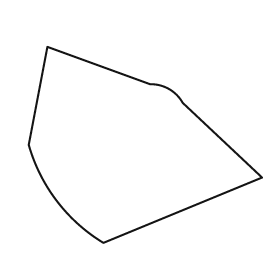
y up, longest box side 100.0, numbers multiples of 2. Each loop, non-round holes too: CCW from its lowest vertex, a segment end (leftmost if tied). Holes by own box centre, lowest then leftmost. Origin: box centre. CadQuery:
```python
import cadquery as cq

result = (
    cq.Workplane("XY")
    .moveTo(-18.0, -42.0)
    .lineTo(50.0, -14.0)
    .lineTo(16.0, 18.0)
    .threePointArc((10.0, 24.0), (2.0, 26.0))
    .lineTo(-42.0, 42.0)
    .lineTo(-50.0, 0.0)
    .threePointArc((-38.0, -24.0), (-18.0, -42.0))
    .close()
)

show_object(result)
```